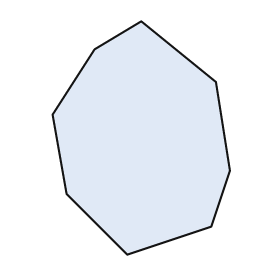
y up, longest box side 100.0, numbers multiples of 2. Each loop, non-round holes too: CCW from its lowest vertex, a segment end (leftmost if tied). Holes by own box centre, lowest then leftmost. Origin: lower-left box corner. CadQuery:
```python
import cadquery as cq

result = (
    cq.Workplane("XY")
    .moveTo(32.0, 0.0)
    .lineTo(68.0, 12.0)
    .lineTo(76.0, 36.0)
    .lineTo(70.0, 74.0)
    .lineTo(38.0, 100.0)
    .lineTo(18.0, 88.0)
    .lineTo(0.0, 60.0)
    .lineTo(6.0, 26.0)
    .close()
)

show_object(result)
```